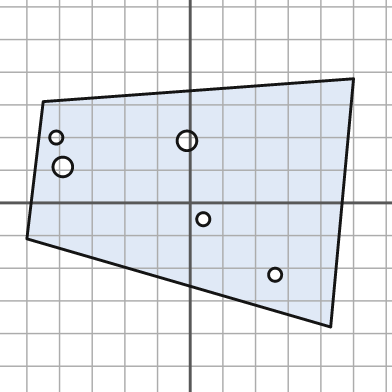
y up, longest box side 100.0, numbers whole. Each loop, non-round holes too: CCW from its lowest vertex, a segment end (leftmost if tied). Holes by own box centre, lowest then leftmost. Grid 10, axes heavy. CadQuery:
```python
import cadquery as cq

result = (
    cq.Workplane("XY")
    .moveTo(43.0, -38.0)
    .lineTo(50.0, 38.0)
    .lineTo(-45.0, 31.0)
    .lineTo(-50.0, -11.0)
    .close()
    .moveTo(26.0, -22.0)
    .circle(2.0)
    .moveTo(4.0, -5.0)
    .circle(2.0)
    .moveTo(-39.0, 11.0)
    .circle(3.0)
    .moveTo(-1.0, 19.0)
    .circle(3.0)
    .moveTo(-41.0, 20.0)
    .circle(2.0)
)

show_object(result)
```